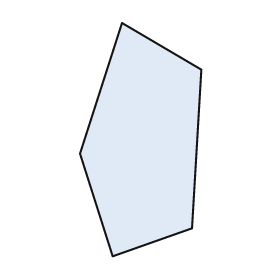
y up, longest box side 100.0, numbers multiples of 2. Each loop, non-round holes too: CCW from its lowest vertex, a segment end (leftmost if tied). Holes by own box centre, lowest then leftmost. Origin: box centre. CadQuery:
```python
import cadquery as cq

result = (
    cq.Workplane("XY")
    .moveTo(-12.0, -50.0)
    .lineTo(22.0, -38.0)
    .lineTo(26.0, 30.0)
    .lineTo(-8.0, 50.0)
    .lineTo(-26.0, -6.0)
    .close()
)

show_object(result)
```